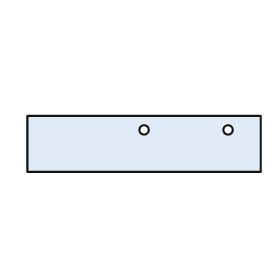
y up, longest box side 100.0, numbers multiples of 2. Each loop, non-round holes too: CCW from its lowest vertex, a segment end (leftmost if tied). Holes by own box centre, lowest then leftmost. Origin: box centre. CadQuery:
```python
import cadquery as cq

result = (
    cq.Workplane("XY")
    .moveTo(-50.0, -12.0)
    .lineTo(50.0, -12.0)
    .lineTo(50.0, 12.0)
    .lineTo(-50.0, 12.0)
    .close()
    .moveTo(0.0, 6.0)
    .circle(2.0)
    .moveTo(36.0, 6.0)
    .circle(2.0)
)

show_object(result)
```